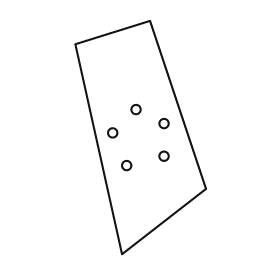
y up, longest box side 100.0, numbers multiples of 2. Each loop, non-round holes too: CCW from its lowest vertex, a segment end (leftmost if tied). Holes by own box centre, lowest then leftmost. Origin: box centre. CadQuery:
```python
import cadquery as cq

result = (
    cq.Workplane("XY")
    .moveTo(-8.0, -50.0)
    .lineTo(28.0, -22.0)
    .lineTo(4.0, 50.0)
    .lineTo(-28.0, 40.0)
    .close()
    .moveTo(-6.0, -12.0)
    .circle(2.0)
    .moveTo(10.0, -8.0)
    .circle(2.0)
    .moveTo(-12.0, 2.0)
    .circle(2.0)
    .moveTo(10.0, 6.0)
    .circle(2.0)
    .moveTo(-2.0, 12.0)
    .circle(2.0)
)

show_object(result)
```